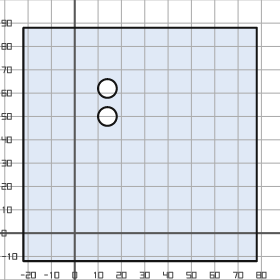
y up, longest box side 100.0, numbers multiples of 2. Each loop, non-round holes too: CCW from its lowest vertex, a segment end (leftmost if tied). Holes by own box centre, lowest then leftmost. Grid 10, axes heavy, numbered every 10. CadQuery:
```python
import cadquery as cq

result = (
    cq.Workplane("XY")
    .moveTo(-22.0, -12.0)
    .lineTo(78.0, -12.0)
    .lineTo(78.0, 88.0)
    .lineTo(-22.0, 88.0)
    .close()
    .moveTo(14.0, 50.0)
    .circle(4.0)
    .moveTo(14.0, 62.0)
    .circle(4.0)
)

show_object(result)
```